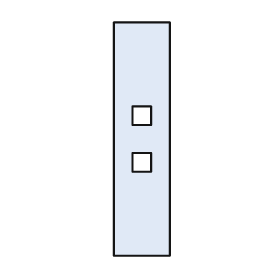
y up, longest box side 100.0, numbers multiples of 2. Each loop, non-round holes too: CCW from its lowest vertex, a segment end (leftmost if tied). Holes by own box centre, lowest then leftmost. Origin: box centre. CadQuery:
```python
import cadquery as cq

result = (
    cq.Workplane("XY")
    .moveTo(-12.0, -50.0)
    .lineTo(12.0, -50.0)
    .lineTo(12.0, 50.0)
    .lineTo(-12.0, 50.0)
    .close()
    .moveTo(-4.0, -14.0)
    .lineTo(4.0, -14.0)
    .lineTo(4.0, -6.0)
    .lineTo(-4.0, -6.0)
    .close()
    .moveTo(-4.0, 6.0)
    .lineTo(4.0, 6.0)
    .lineTo(4.0, 14.0)
    .lineTo(-4.0, 14.0)
    .close()
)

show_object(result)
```